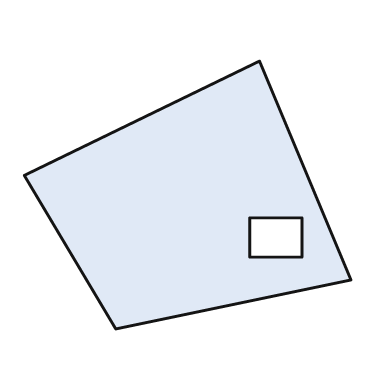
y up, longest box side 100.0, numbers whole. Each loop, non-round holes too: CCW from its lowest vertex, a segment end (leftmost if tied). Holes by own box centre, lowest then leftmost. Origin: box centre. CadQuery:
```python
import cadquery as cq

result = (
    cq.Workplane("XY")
    .moveTo(-22.0, -41.0)
    .lineTo(50.0, -26.0)
    .lineTo(22.0, 41.0)
    .lineTo(-50.0, 6.0)
    .close()
    .moveTo(19.0, -19.0)
    .lineTo(35.0, -19.0)
    .lineTo(35.0, -7.0)
    .lineTo(19.0, -7.0)
    .close()
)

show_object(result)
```